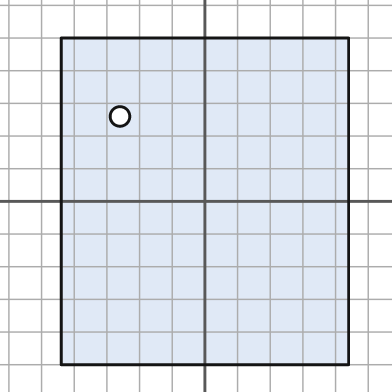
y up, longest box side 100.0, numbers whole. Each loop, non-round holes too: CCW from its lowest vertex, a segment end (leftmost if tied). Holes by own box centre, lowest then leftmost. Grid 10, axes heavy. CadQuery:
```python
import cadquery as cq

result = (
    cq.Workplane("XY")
    .moveTo(-44.0, -50.0)
    .lineTo(44.0, -50.0)
    .lineTo(44.0, 50.0)
    .lineTo(-44.0, 50.0)
    .close()
    .moveTo(-26.0, 26.0)
    .circle(3.0)
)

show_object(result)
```